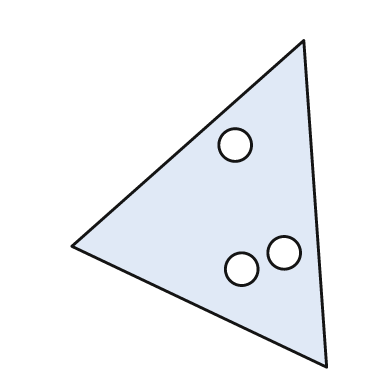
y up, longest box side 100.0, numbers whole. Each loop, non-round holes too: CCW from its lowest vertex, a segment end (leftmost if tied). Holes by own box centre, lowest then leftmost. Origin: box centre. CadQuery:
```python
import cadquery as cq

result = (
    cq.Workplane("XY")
    .moveTo(39.0, -50.0)
    .lineTo(32.0, 50.0)
    .lineTo(-39.0, -13.0)
    .close()
    .moveTo(13.0, -20.0)
    .circle(5.0)
    .moveTo(26.0, -15.0)
    .circle(5.0)
    .moveTo(11.0, 18.0)
    .circle(5.0)
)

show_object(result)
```